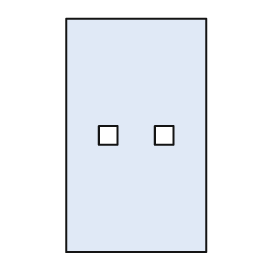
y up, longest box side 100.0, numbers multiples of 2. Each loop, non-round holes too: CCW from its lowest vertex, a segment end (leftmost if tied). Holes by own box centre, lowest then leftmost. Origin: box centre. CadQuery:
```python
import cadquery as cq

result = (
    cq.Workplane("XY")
    .moveTo(-30.0, -50.0)
    .lineTo(30.0, -50.0)
    .lineTo(30.0, 50.0)
    .lineTo(-30.0, 50.0)
    .close()
    .moveTo(-16.0, -4.0)
    .lineTo(-8.0, -4.0)
    .lineTo(-8.0, 4.0)
    .lineTo(-16.0, 4.0)
    .close()
    .moveTo(8.0, -4.0)
    .lineTo(16.0, -4.0)
    .lineTo(16.0, 4.0)
    .lineTo(8.0, 4.0)
    .close()
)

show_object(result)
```